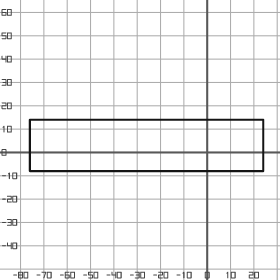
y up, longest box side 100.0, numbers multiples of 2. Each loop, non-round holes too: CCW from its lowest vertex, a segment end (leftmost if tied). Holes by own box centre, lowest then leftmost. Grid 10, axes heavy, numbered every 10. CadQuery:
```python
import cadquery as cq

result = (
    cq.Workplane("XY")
    .moveTo(-76.0, -8.0)
    .lineTo(24.0, -8.0)
    .lineTo(24.0, 14.0)
    .lineTo(-76.0, 14.0)
    .close()
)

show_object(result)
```